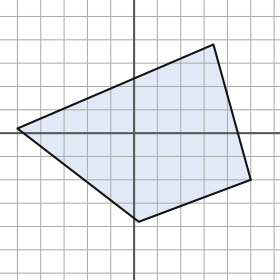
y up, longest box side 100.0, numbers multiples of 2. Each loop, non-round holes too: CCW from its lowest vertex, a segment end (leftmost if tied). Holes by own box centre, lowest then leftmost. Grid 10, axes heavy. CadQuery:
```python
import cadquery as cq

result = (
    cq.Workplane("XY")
    .moveTo(2.0, -38.0)
    .lineTo(50.0, -20.0)
    .lineTo(34.0, 38.0)
    .lineTo(-50.0, 2.0)
    .close()
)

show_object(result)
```